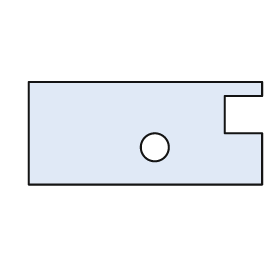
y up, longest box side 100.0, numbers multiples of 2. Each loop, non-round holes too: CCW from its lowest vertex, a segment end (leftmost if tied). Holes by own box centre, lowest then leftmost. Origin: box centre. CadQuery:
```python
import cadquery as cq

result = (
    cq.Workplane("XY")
    .moveTo(-50.0, -22.0)
    .lineTo(50.0, -22.0)
    .lineTo(50.0, 0.0)
    .lineTo(34.0, 0.0)
    .lineTo(34.0, 16.0)
    .lineTo(50.0, 16.0)
    .lineTo(50.0, 22.0)
    .lineTo(-50.0, 22.0)
    .close()
    .moveTo(4.0, -6.0)
    .circle(6.0)
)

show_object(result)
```